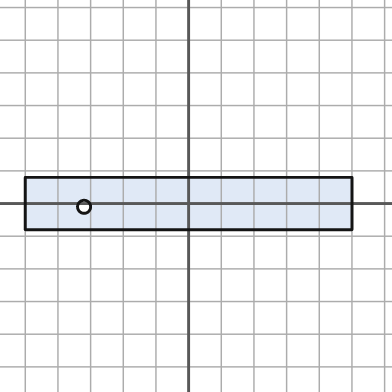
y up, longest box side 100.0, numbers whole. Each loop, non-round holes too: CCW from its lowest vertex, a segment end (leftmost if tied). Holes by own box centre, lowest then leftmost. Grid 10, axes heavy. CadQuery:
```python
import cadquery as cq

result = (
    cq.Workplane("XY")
    .moveTo(-50.0, -8.0)
    .lineTo(50.0, -8.0)
    .lineTo(50.0, 8.0)
    .lineTo(-50.0, 8.0)
    .close()
    .moveTo(-32.0, -1.0)
    .circle(2.0)
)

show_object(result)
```